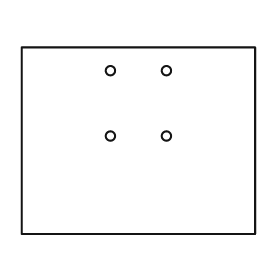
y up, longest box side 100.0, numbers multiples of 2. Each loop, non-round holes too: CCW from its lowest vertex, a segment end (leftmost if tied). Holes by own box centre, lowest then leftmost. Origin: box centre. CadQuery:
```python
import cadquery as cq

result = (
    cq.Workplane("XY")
    .moveTo(-50.0, -40.0)
    .lineTo(50.0, -40.0)
    .lineTo(50.0, 40.0)
    .lineTo(-50.0, 40.0)
    .close()
    .moveTo(-12.0, 2.0)
    .circle(2.0)
    .moveTo(12.0, 2.0)
    .circle(2.0)
    .moveTo(-12.0, 30.0)
    .circle(2.0)
    .moveTo(12.0, 30.0)
    .circle(2.0)
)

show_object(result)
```